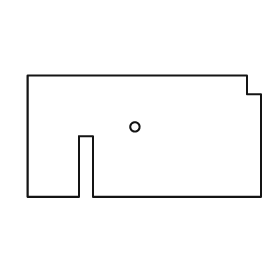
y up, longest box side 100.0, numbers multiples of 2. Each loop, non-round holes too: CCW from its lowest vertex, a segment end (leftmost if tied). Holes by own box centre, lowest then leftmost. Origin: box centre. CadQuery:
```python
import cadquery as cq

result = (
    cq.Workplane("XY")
    .moveTo(-50.0, -26.0)
    .lineTo(-28.0, -26.0)
    .lineTo(-28.0, 0.0)
    .lineTo(-22.0, 0.0)
    .lineTo(-22.0, -26.0)
    .lineTo(50.0, -26.0)
    .lineTo(50.0, 18.0)
    .lineTo(44.0, 18.0)
    .lineTo(44.0, 26.0)
    .lineTo(-50.0, 26.0)
    .close()
    .moveTo(-4.0, 4.0)
    .circle(2.0)
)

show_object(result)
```